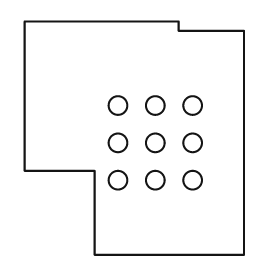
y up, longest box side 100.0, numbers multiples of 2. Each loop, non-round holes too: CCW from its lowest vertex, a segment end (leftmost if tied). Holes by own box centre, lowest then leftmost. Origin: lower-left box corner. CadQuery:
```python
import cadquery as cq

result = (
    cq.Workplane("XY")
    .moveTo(30.0, 0.0)
    .lineTo(94.0, 0.0)
    .lineTo(94.0, 96.0)
    .lineTo(66.0, 96.0)
    .lineTo(66.0, 100.0)
    .lineTo(0.0, 100.0)
    .lineTo(0.0, 36.0)
    .lineTo(30.0, 36.0)
    .close()
    .moveTo(40.0, 32.0)
    .circle(4.0)
    .moveTo(56.0, 32.0)
    .circle(4.0)
    .moveTo(72.0, 32.0)
    .circle(4.0)
    .moveTo(40.0, 48.0)
    .circle(4.0)
    .moveTo(56.0, 48.0)
    .circle(4.0)
    .moveTo(72.0, 48.0)
    .circle(4.0)
    .moveTo(40.0, 64.0)
    .circle(4.0)
    .moveTo(56.0, 64.0)
    .circle(4.0)
    .moveTo(72.0, 64.0)
    .circle(4.0)
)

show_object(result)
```